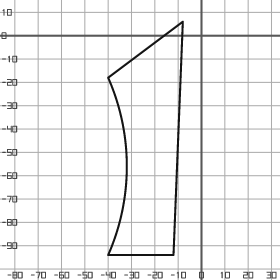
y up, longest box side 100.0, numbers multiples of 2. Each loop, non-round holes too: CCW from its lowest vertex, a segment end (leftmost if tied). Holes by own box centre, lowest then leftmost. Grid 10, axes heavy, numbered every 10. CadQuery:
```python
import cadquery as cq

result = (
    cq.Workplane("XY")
    .moveTo(-40.0, -94.0)
    .lineTo(-12.0, -94.0)
    .lineTo(-8.0, 6.0)
    .lineTo(-40.0, -18.0)
    .threePointArc((-32.0, -56.0), (-40.0, -94.0))
    .close()
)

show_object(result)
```